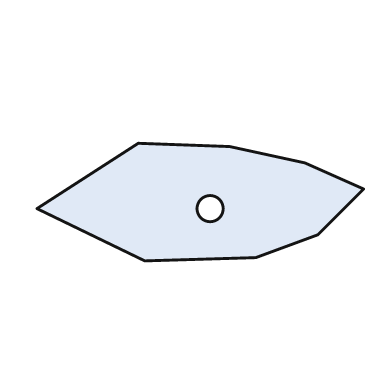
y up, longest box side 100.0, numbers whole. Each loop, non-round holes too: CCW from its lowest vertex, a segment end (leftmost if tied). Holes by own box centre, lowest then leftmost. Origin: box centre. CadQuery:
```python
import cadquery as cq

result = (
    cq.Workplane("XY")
    .moveTo(-17.0, -18.0)
    .lineTo(17.0, -17.0)
    .lineTo(36.0, -10.0)
    .lineTo(50.0, 4.0)
    .lineTo(32.0, 12.0)
    .lineTo(9.0, 17.0)
    .lineTo(-19.0, 18.0)
    .lineTo(-50.0, -2.0)
    .close()
    .moveTo(3.0, -2.0)
    .circle(4.0)
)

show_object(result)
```